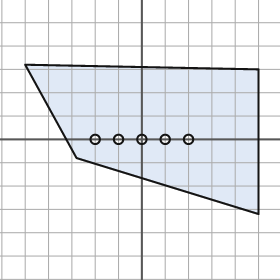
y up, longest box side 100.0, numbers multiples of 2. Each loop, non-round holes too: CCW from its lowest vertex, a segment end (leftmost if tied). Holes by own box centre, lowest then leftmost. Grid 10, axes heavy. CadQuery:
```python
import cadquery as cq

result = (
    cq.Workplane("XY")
    .moveTo(50.0, -32.0)
    .lineTo(50.0, 30.0)
    .lineTo(-50.0, 32.0)
    .lineTo(-28.0, -8.0)
    .close()
    .moveTo(-20.0, 0.0)
    .circle(2.0)
    .moveTo(-10.0, 0.0)
    .circle(2.0)
    .moveTo(0.0, 0.0)
    .circle(2.0)
    .moveTo(10.0, 0.0)
    .circle(2.0)
    .moveTo(20.0, 0.0)
    .circle(2.0)
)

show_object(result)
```